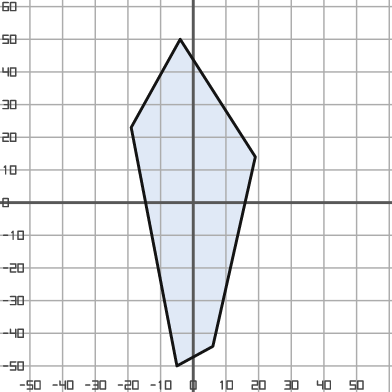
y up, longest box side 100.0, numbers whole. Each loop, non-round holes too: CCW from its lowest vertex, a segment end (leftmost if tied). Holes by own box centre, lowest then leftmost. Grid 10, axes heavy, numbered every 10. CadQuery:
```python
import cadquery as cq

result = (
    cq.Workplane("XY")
    .moveTo(-5.0, -50.0)
    .lineTo(6.0, -44.0)
    .lineTo(19.0, 14.0)
    .lineTo(-4.0, 50.0)
    .lineTo(-19.0, 23.0)
    .close()
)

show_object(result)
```